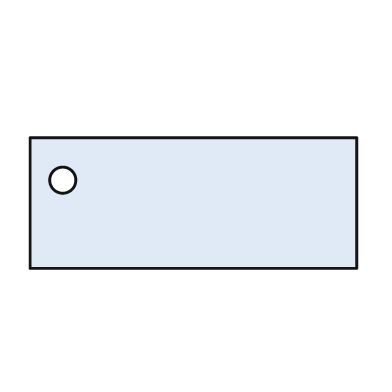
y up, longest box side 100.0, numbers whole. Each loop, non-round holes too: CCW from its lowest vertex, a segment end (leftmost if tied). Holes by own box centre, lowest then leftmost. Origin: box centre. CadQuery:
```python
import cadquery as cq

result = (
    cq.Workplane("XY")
    .moveTo(-50.0, -20.0)
    .lineTo(50.0, -20.0)
    .lineTo(50.0, 20.0)
    .lineTo(-50.0, 20.0)
    .close()
    .moveTo(-40.0, 7.0)
    .circle(4.0)
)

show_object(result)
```